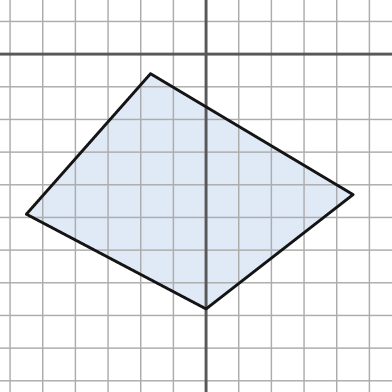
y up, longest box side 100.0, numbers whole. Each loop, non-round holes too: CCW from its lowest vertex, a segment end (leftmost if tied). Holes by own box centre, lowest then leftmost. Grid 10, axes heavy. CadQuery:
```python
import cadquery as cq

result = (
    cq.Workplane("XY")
    .moveTo(0.0, -78.0)
    .lineTo(45.0, -43.0)
    .lineTo(-17.0, -6.0)
    .lineTo(-55.0, -49.0)
    .close()
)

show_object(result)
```